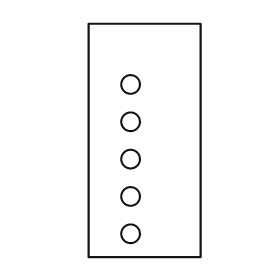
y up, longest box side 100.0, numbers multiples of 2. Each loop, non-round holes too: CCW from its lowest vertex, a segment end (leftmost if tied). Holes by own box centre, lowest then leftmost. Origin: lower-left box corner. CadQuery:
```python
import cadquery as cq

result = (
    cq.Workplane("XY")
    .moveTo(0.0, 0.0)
    .lineTo(48.0, 0.0)
    .lineTo(48.0, 100.0)
    .lineTo(0.0, 100.0)
    .close()
    .moveTo(18.0, 10.0)
    .circle(4.0)
    .moveTo(18.0, 26.0)
    .circle(4.0)
    .moveTo(18.0, 42.0)
    .circle(4.0)
    .moveTo(18.0, 58.0)
    .circle(4.0)
    .moveTo(18.0, 74.0)
    .circle(4.0)
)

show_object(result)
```